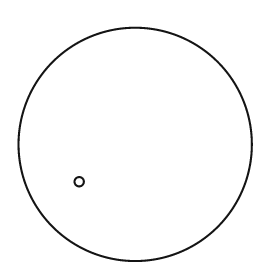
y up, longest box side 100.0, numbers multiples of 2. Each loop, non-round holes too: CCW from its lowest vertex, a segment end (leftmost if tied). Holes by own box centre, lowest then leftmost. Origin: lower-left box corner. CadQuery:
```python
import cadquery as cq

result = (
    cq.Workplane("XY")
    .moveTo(50.0, 50.0)
    .circle(50.0)
    .moveTo(26.0, 34.0)
    .circle(2.0)
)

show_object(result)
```